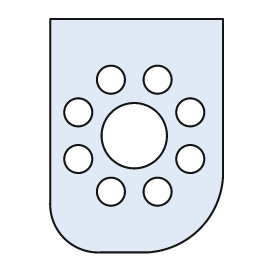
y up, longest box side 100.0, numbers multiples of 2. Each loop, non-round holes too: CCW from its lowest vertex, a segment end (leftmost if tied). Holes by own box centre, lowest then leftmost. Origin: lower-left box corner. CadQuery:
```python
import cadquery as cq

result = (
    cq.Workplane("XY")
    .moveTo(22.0, 0.0)
    .lineTo(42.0, 0.0)
    .threePointArc((64.0, 10.0), (74.0, 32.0))
    .lineTo(74.0, 100.0)
    .lineTo(0.0, 100.0)
    .lineTo(0.0, 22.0)
    .threePointArc((6.0, 6.0), (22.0, 0.0))
    .close()
    .moveTo(26.0, 26.0)
    .circle(6.0)
    .moveTo(46.0, 26.0)
    .circle(6.0)
    .moveTo(12.0, 40.0)
    .circle(6.0)
    .moveTo(60.0, 40.0)
    .circle(6.0)
    .moveTo(36.0, 50.0)
    .circle(14.0)
    .moveTo(12.0, 60.0)
    .circle(6.0)
    .moveTo(60.0, 60.0)
    .circle(6.0)
    .moveTo(26.0, 74.0)
    .circle(6.0)
    .moveTo(46.0, 74.0)
    .circle(6.0)
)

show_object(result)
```